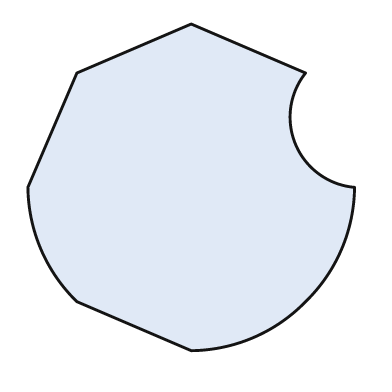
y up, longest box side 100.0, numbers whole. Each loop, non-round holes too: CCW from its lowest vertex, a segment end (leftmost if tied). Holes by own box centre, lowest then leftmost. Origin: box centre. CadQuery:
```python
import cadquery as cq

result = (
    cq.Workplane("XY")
    .moveTo(0.0, -50.0)
    .threePointArc((19.0, -46.0), (35.0, -35.0))
    .threePointArc((46.0, -19.0), (50.0, 0.0))
    .threePointArc((32.0, 13.0), (35.0, 35.0))
    .lineTo(0.0, 50.0)
    .lineTo(-35.0, 35.0)
    .lineTo(-50.0, 0.0)
    .threePointArc((-46.0, -19.0), (-35.0, -35.0))
    .close()
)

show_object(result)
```